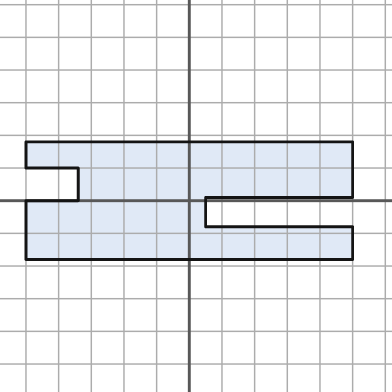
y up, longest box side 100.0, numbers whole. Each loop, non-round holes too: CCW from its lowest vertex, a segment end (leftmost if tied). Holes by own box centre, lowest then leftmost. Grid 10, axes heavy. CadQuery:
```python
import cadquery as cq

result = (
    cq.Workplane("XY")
    .moveTo(-50.0, -18.0)
    .lineTo(50.0, -18.0)
    .lineTo(50.0, -8.0)
    .lineTo(5.0, -8.0)
    .lineTo(5.0, 1.0)
    .lineTo(50.0, 1.0)
    .lineTo(50.0, 18.0)
    .lineTo(-50.0, 18.0)
    .lineTo(-50.0, 10.0)
    .lineTo(-34.0, 10.0)
    .lineTo(-34.0, 0.0)
    .lineTo(-50.0, 0.0)
    .close()
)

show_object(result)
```